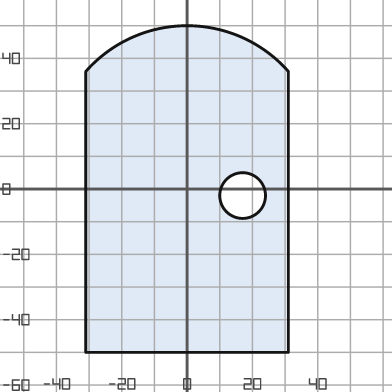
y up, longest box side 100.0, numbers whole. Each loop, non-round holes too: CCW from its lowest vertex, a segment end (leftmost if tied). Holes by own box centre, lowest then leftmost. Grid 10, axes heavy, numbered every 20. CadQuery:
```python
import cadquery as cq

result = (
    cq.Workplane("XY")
    .moveTo(-31.0, -50.0)
    .lineTo(31.0, -50.0)
    .lineTo(31.0, 36.0)
    .threePointArc((0.0, 50.0), (-31.0, 36.0))
    .close()
    .moveTo(17.0, -2.0)
    .circle(7.0)
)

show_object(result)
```